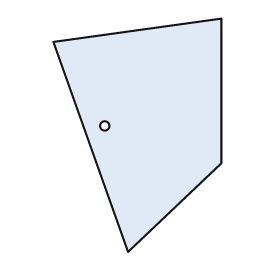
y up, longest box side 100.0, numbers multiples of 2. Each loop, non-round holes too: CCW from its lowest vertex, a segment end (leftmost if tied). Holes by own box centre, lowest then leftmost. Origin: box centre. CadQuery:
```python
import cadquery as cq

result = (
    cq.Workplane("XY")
    .moveTo(-4.0, -50.0)
    .lineTo(36.0, -12.0)
    .lineTo(36.0, 50.0)
    .lineTo(-36.0, 40.0)
    .close()
    .moveTo(-14.0, 4.0)
    .circle(2.0)
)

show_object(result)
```